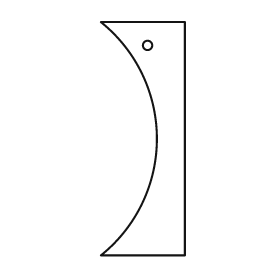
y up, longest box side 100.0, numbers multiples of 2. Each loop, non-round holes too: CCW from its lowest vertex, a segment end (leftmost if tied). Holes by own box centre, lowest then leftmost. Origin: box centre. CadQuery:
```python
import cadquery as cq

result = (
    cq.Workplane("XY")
    .moveTo(-18.0, -50.0)
    .lineTo(18.0, -50.0)
    .lineTo(18.0, 50.0)
    .lineTo(-18.0, 50.0)
    .threePointArc((6.0, 0.0), (-18.0, -50.0))
    .close()
    .moveTo(2.0, 40.0)
    .circle(2.0)
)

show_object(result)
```